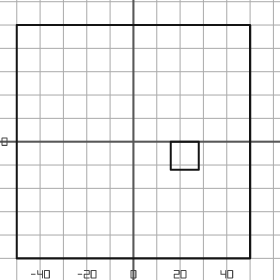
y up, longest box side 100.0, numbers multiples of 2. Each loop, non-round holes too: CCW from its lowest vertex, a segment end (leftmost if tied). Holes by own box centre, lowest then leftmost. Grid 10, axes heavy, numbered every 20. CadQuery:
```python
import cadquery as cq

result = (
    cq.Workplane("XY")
    .moveTo(-50.0, -50.0)
    .lineTo(50.0, -50.0)
    .lineTo(50.0, 50.0)
    .lineTo(-50.0, 50.0)
    .close()
    .moveTo(16.0, -12.0)
    .lineTo(28.0, -12.0)
    .lineTo(28.0, 0.0)
    .lineTo(16.0, 0.0)
    .close()
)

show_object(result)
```